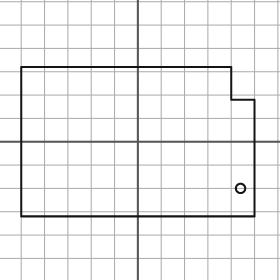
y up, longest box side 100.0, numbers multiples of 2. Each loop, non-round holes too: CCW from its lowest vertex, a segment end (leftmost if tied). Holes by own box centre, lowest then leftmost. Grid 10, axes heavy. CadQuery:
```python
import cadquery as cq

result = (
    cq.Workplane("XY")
    .moveTo(-50.0, -32.0)
    .lineTo(50.0, -32.0)
    .lineTo(50.0, 18.0)
    .lineTo(40.0, 18.0)
    .lineTo(40.0, 32.0)
    .lineTo(-50.0, 32.0)
    .close()
    .moveTo(44.0, -20.0)
    .circle(2.0)
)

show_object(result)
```